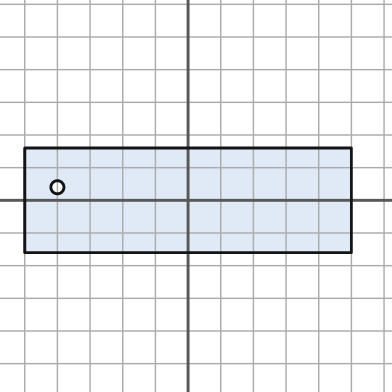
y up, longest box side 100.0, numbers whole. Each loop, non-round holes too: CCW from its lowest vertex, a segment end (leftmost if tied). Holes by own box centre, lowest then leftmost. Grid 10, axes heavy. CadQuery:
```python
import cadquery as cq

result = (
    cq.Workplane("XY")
    .moveTo(-50.0, -16.0)
    .lineTo(50.0, -16.0)
    .lineTo(50.0, 16.0)
    .lineTo(-50.0, 16.0)
    .close()
    .moveTo(-40.0, 4.0)
    .circle(2.0)
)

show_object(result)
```